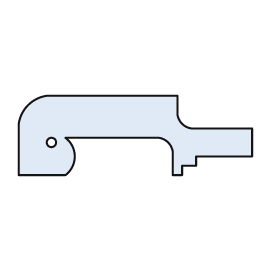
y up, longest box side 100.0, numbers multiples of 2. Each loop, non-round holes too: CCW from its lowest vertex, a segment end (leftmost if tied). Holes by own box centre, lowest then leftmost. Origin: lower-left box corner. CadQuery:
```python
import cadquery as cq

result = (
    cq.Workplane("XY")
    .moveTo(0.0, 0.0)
    .lineTo(20.0, 0.0)
    .threePointArc((24.0, 8.0), (20.0, 16.0))
    .lineTo(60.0, 16.0)
    .threePointArc((64.0, 14.0), (66.0, 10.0))
    .lineTo(66.0, 0.0)
    .lineTo(70.0, 0.0)
    .lineTo(70.0, 4.0)
    .lineTo(76.0, 4.0)
    .lineTo(76.0, 8.0)
    .lineTo(100.0, 8.0)
    .lineTo(100.0, 20.0)
    .lineTo(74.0, 20.0)
    .threePointArc((70.0, 22.0), (68.0, 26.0))
    .lineTo(68.0, 34.0)
    .lineTo(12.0, 34.0)
    .threePointArc((4.0, 30.0), (0.0, 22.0))
    .close()
    .moveTo(14.0, 14.0)
    .circle(2.0)
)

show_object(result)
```